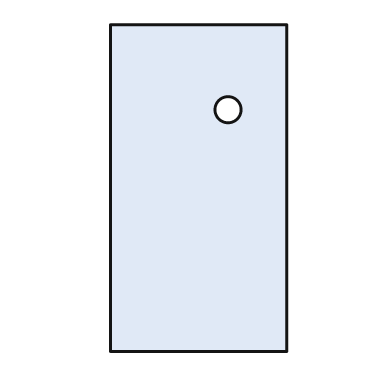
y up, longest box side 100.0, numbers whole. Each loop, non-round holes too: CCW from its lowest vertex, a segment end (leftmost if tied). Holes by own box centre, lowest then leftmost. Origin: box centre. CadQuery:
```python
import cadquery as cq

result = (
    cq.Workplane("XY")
    .moveTo(-27.0, -50.0)
    .lineTo(27.0, -50.0)
    .lineTo(27.0, 50.0)
    .lineTo(-27.0, 50.0)
    .close()
    .moveTo(9.0, 24.0)
    .circle(4.0)
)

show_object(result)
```